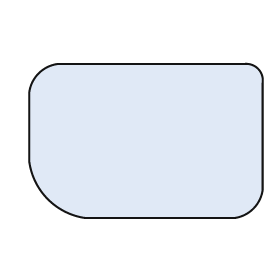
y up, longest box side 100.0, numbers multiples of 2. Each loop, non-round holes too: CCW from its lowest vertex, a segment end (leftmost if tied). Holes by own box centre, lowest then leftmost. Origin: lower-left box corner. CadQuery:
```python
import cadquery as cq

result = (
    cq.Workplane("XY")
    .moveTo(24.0, 0.0)
    .lineTo(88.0, 0.0)
    .threePointArc((96.0, 4.0), (100.0, 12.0))
    .lineTo(100.0, 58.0)
    .threePointArc((98.0, 64.0), (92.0, 66.0))
    .lineTo(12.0, 66.0)
    .threePointArc((4.0, 62.0), (0.0, 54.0))
    .lineTo(0.0, 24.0)
    .threePointArc((8.0, 8.0), (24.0, 0.0))
    .close()
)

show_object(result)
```